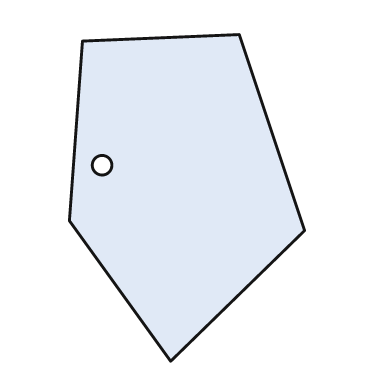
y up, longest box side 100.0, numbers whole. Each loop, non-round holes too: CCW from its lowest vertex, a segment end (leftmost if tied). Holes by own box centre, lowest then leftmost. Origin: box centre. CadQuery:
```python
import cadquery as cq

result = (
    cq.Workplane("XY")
    .moveTo(-5.0, -50.0)
    .lineTo(36.0, -10.0)
    .lineTo(16.0, 50.0)
    .lineTo(-32.0, 48.0)
    .lineTo(-36.0, -7.0)
    .close()
    .moveTo(-26.0, 10.0)
    .circle(3.0)
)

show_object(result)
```